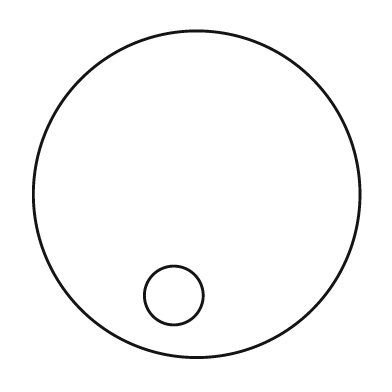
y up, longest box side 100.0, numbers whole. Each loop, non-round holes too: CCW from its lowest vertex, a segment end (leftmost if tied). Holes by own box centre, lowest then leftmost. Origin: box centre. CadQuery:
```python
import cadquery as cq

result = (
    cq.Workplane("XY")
    .moveTo(0.0, 0.0)
    .circle(50.0)
    .moveTo(-7.0, -31.0)
    .circle(9.0)
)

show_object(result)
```